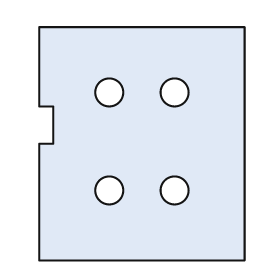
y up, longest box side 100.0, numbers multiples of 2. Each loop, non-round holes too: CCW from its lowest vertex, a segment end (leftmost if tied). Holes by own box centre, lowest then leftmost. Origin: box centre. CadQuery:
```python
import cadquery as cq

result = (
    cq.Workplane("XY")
    .moveTo(-44.0, -50.0)
    .lineTo(44.0, -50.0)
    .lineTo(44.0, 50.0)
    .lineTo(-44.0, 50.0)
    .lineTo(-44.0, 16.0)
    .lineTo(-38.0, 16.0)
    .lineTo(-38.0, 0.0)
    .lineTo(-44.0, 0.0)
    .close()
    .moveTo(-14.0, -20.0)
    .circle(6.0)
    .moveTo(14.0, -20.0)
    .circle(6.0)
    .moveTo(-14.0, 22.0)
    .circle(6.0)
    .moveTo(14.0, 22.0)
    .circle(6.0)
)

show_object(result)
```